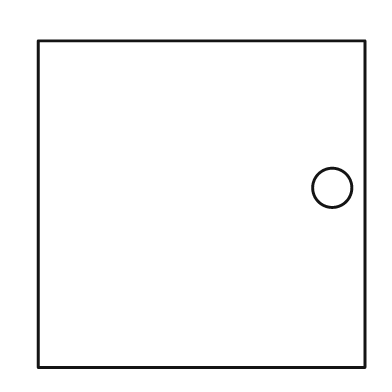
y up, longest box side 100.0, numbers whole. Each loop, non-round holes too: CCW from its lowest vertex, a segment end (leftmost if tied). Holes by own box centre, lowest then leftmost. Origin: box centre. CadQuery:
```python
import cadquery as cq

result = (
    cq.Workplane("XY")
    .moveTo(-50.0, -50.0)
    .lineTo(50.0, -50.0)
    .lineTo(50.0, 50.0)
    .lineTo(-50.0, 50.0)
    .close()
    .moveTo(40.0, 5.0)
    .circle(6.0)
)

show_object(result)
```